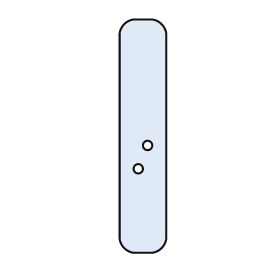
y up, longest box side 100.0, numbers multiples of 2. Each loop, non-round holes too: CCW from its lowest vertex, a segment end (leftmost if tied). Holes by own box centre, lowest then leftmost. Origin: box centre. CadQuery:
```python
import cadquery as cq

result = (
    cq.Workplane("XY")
    .moveTo(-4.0, -50.0)
    .lineTo(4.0, -50.0)
    .threePointArc((8.0, -48.0), (10.0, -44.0))
    .lineTo(10.0, 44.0)
    .threePointArc((8.0, 48.0), (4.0, 50.0))
    .lineTo(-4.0, 50.0)
    .threePointArc((-8.0, 48.0), (-10.0, 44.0))
    .lineTo(-10.0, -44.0)
    .threePointArc((-8.0, -48.0), (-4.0, -50.0))
    .close()
    .moveTo(-2.0, -14.0)
    .circle(2.0)
    .moveTo(2.0, -4.0)
    .circle(2.0)
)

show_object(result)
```